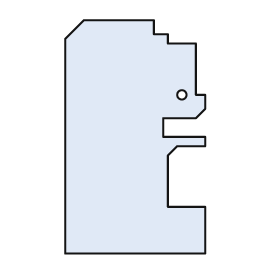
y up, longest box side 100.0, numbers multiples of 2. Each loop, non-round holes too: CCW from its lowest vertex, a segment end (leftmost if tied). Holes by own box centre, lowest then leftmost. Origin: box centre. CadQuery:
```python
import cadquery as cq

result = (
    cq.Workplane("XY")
    .moveTo(-30.0, -50.0)
    .lineTo(30.0, -50.0)
    .lineTo(30.0, -30.0)
    .lineTo(14.0, -30.0)
    .lineTo(14.0, -8.0)
    .lineTo(18.0, -4.0)
    .lineTo(30.0, -4.0)
    .lineTo(30.0, 0.0)
    .lineTo(12.0, 0.0)
    .lineTo(12.0, 8.0)
    .lineTo(26.0, 8.0)
    .lineTo(30.0, 12.0)
    .lineTo(30.0, 18.0)
    .lineTo(26.0, 18.0)
    .lineTo(26.0, 40.0)
    .lineTo(14.0, 40.0)
    .lineTo(14.0, 44.0)
    .lineTo(8.0, 44.0)
    .lineTo(8.0, 50.0)
    .lineTo(-22.0, 50.0)
    .lineTo(-30.0, 42.0)
    .close()
    .moveTo(20.0, 18.0)
    .circle(2.0)
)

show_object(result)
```